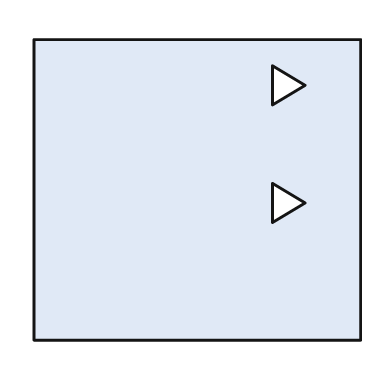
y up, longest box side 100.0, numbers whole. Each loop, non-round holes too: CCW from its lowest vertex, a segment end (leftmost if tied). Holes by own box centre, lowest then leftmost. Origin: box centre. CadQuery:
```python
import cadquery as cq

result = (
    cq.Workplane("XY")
    .moveTo(-50.0, -46.0)
    .lineTo(50.0, -46.0)
    .lineTo(50.0, 46.0)
    .lineTo(-50.0, 46.0)
    .close()
    .moveTo(23.0, -10.0)
    .lineTo(33.0, -4.0)
    .lineTo(23.0, 2.0)
    .close()
    .moveTo(23.0, 26.0)
    .lineTo(33.0, 32.0)
    .lineTo(23.0, 38.0)
    .close()
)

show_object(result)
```